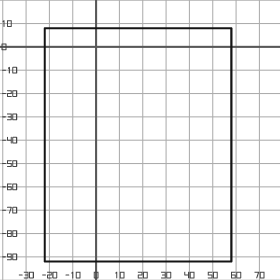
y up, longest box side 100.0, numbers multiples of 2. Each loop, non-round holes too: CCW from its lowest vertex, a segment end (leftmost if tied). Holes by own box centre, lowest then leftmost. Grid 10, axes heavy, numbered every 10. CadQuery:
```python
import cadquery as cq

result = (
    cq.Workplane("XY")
    .moveTo(-22.0, -92.0)
    .lineTo(58.0, -92.0)
    .lineTo(58.0, 8.0)
    .lineTo(-22.0, 8.0)
    .close()
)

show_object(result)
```